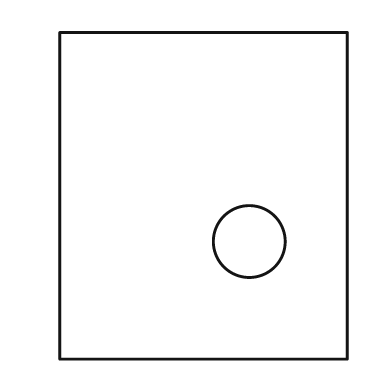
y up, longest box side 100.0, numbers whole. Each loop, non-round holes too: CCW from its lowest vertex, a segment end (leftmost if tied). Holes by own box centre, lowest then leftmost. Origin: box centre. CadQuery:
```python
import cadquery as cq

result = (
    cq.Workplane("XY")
    .moveTo(-44.0, -50.0)
    .lineTo(44.0, -50.0)
    .lineTo(44.0, 50.0)
    .lineTo(-44.0, 50.0)
    .close()
    .moveTo(14.0, -14.0)
    .circle(11.0)
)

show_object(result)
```